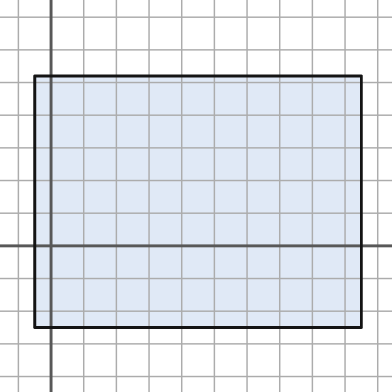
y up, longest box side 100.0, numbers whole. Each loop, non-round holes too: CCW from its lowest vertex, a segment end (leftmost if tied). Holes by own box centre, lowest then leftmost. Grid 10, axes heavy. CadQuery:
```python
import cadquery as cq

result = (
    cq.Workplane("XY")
    .moveTo(-5.0, -25.0)
    .lineTo(95.0, -25.0)
    .lineTo(95.0, 52.0)
    .lineTo(-5.0, 52.0)
    .close()
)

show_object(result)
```